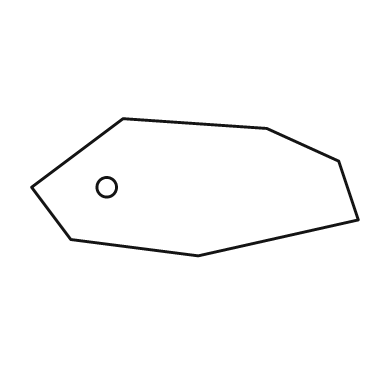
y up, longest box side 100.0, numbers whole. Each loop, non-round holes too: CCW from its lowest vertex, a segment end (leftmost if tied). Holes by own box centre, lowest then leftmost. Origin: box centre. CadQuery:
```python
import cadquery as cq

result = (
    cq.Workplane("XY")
    .moveTo(1.0, -21.0)
    .lineTo(50.0, -10.0)
    .lineTo(44.0, 8.0)
    .lineTo(22.0, 18.0)
    .lineTo(-22.0, 21.0)
    .lineTo(-50.0, 0.0)
    .lineTo(-38.0, -16.0)
    .close()
    .moveTo(-27.0, 0.0)
    .circle(3.0)
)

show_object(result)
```